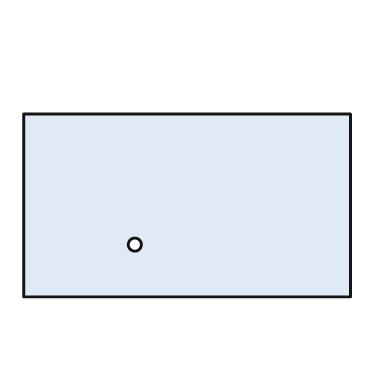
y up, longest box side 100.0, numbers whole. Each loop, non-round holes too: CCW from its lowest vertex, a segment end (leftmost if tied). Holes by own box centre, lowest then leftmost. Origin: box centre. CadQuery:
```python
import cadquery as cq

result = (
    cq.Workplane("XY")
    .moveTo(-50.0, -28.0)
    .lineTo(50.0, -28.0)
    .lineTo(50.0, 28.0)
    .lineTo(-50.0, 28.0)
    .close()
    .moveTo(-16.0, -12.0)
    .circle(2.0)
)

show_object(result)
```